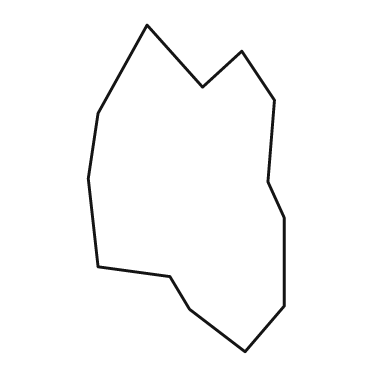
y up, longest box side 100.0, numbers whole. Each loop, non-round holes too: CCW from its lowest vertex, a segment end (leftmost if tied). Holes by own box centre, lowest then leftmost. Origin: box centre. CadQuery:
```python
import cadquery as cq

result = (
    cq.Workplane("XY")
    .moveTo(18.0, -50.0)
    .lineTo(30.0, -36.0)
    .lineTo(30.0, -9.0)
    .lineTo(25.0, 2.0)
    .lineTo(27.0, 27.0)
    .lineTo(17.0, 42.0)
    .lineTo(5.0, 31.0)
    .lineTo(-12.0, 50.0)
    .lineTo(-27.0, 23.0)
    .lineTo(-30.0, 3.0)
    .lineTo(-27.0, -24.0)
    .lineTo(-5.0, -27.0)
    .lineTo(1.0, -37.0)
    .close()
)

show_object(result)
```